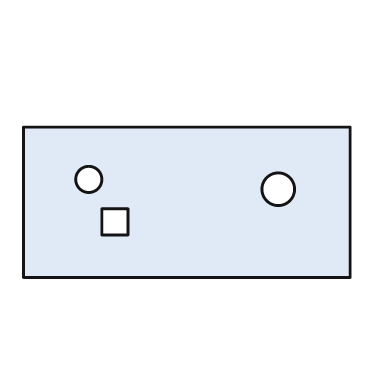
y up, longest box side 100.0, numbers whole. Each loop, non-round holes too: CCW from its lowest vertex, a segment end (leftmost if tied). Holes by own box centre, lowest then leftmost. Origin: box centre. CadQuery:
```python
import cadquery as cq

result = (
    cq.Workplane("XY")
    .moveTo(-50.0, -23.0)
    .lineTo(50.0, -23.0)
    .lineTo(50.0, 23.0)
    .lineTo(-50.0, 23.0)
    .close()
    .moveTo(-26.0, -10.0)
    .lineTo(-18.0, -10.0)
    .lineTo(-18.0, -2.0)
    .lineTo(-26.0, -2.0)
    .close()
    .moveTo(28.0, 4.0)
    .circle(5.0)
    .moveTo(-30.0, 7.0)
    .circle(4.0)
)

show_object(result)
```